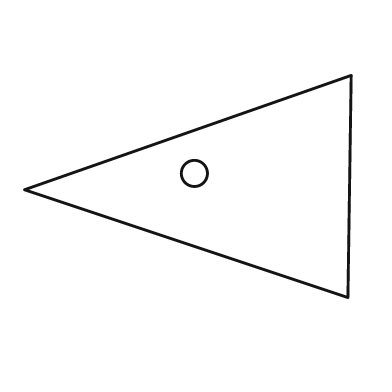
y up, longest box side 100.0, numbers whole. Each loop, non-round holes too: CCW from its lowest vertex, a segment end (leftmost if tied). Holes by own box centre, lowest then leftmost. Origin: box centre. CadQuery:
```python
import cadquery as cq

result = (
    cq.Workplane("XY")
    .moveTo(49.0, -34.0)
    .lineTo(50.0, 34.0)
    .lineTo(-50.0, -1.0)
    .close()
    .moveTo(2.0, 4.0)
    .circle(4.0)
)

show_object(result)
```